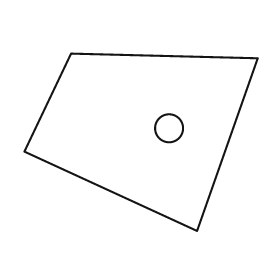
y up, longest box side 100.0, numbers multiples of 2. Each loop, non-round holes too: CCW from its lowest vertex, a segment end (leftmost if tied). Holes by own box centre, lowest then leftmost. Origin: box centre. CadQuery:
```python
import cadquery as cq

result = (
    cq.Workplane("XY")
    .moveTo(24.0, -38.0)
    .lineTo(50.0, 36.0)
    .lineTo(-30.0, 38.0)
    .lineTo(-50.0, -4.0)
    .close()
    .moveTo(12.0, 6.0)
    .circle(6.0)
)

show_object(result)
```